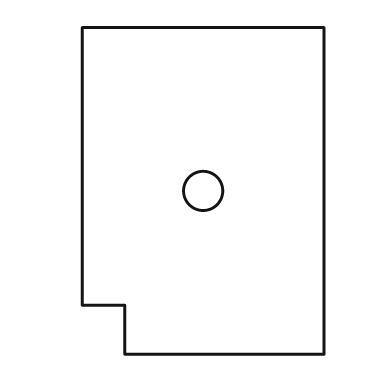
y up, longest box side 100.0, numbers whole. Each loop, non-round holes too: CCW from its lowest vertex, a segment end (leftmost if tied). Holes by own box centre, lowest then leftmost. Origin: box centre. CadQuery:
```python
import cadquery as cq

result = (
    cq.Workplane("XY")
    .moveTo(-24.0, -50.0)
    .lineTo(37.0, -50.0)
    .lineTo(37.0, 50.0)
    .lineTo(-37.0, 50.0)
    .lineTo(-37.0, -35.0)
    .lineTo(-24.0, -35.0)
    .close()
    .moveTo(0.0, 0.0)
    .circle(6.0)
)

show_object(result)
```